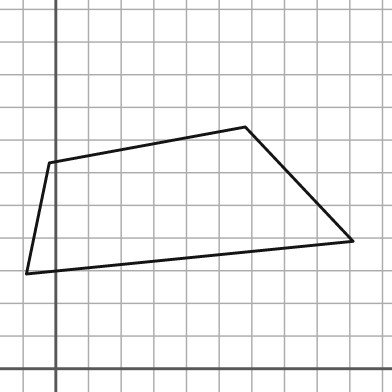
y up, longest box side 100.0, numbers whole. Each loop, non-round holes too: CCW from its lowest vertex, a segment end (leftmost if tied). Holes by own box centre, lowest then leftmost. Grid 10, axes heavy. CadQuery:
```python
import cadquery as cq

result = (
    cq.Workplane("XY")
    .moveTo(-9.0, 29.0)
    .lineTo(91.0, 39.0)
    .lineTo(58.0, 74.0)
    .lineTo(-2.0, 63.0)
    .close()
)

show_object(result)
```